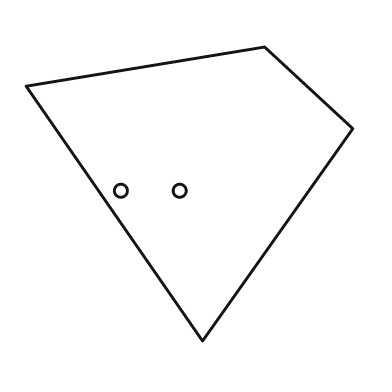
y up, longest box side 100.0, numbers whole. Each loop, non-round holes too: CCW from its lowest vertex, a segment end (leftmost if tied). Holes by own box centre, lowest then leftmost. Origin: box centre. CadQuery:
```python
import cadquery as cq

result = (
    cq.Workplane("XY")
    .moveTo(4.0, -45.0)
    .lineTo(50.0, 20.0)
    .lineTo(23.0, 45.0)
    .lineTo(-50.0, 33.0)
    .close()
    .moveTo(-21.0, 1.0)
    .circle(2.0)
    .moveTo(-3.0, 1.0)
    .circle(2.0)
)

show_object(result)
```